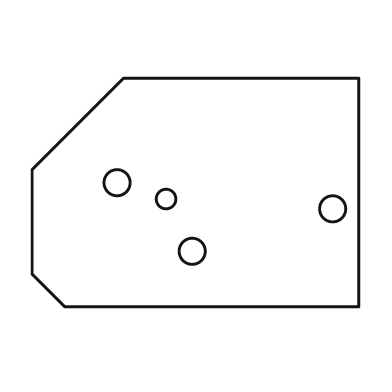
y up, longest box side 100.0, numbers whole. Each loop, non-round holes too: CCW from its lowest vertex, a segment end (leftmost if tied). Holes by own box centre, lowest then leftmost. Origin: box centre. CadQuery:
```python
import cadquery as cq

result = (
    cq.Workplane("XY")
    .moveTo(-40.0, -35.0)
    .lineTo(50.0, -35.0)
    .lineTo(50.0, 35.0)
    .lineTo(-22.0, 35.0)
    .lineTo(-50.0, 7.0)
    .lineTo(-50.0, -25.0)
    .close()
    .moveTo(-1.0, -18.0)
    .circle(4.0)
    .moveTo(42.0, -5.0)
    .circle(4.0)
    .moveTo(-9.0, -2.0)
    .circle(3.0)
    .moveTo(-24.0, 3.0)
    .circle(4.0)
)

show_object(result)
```